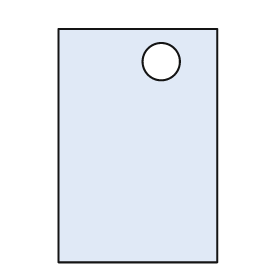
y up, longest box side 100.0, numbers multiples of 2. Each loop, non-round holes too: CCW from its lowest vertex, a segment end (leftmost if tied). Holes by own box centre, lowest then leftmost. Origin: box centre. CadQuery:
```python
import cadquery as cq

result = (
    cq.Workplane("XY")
    .moveTo(-34.0, -50.0)
    .lineTo(34.0, -50.0)
    .lineTo(34.0, 50.0)
    .lineTo(-34.0, 50.0)
    .close()
    .moveTo(10.0, 36.0)
    .circle(8.0)
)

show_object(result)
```